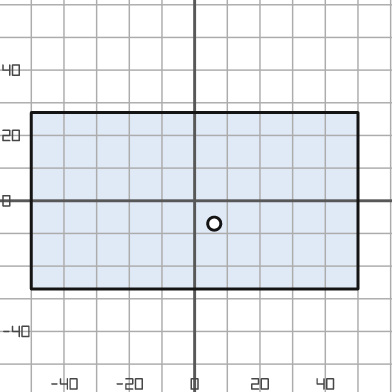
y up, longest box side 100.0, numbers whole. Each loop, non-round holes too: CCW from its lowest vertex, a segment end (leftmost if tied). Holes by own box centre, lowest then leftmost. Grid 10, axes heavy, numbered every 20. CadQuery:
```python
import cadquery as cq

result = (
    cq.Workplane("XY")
    .moveTo(-50.0, -27.0)
    .lineTo(50.0, -27.0)
    .lineTo(50.0, 27.0)
    .lineTo(-50.0, 27.0)
    .close()
    .moveTo(6.0, -7.0)
    .circle(2.0)
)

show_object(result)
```